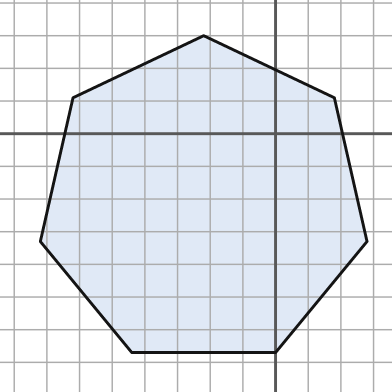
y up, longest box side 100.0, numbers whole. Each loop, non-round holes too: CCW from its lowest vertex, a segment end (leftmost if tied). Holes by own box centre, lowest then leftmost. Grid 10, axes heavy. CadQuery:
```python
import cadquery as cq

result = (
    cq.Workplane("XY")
    .moveTo(-44.0, -67.0)
    .lineTo(0.0, -67.0)
    .lineTo(28.0, -33.0)
    .lineTo(18.0, 11.0)
    .lineTo(-22.0, 30.0)
    .lineTo(-62.0, 11.0)
    .lineTo(-72.0, -33.0)
    .close()
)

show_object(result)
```